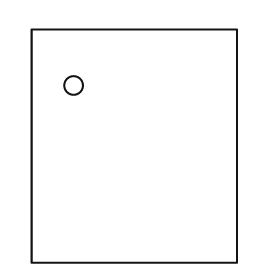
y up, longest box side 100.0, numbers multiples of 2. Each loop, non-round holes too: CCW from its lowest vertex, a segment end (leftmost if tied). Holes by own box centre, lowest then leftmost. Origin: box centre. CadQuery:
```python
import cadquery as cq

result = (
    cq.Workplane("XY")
    .moveTo(-44.0, -50.0)
    .lineTo(44.0, -50.0)
    .lineTo(44.0, 50.0)
    .lineTo(-44.0, 50.0)
    .close()
    .moveTo(-26.0, 26.0)
    .circle(4.0)
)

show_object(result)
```